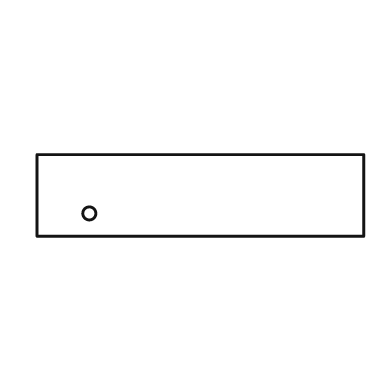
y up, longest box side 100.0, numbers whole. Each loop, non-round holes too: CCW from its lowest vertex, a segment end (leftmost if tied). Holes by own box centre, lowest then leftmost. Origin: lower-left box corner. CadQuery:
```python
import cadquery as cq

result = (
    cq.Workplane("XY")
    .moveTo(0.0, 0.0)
    .lineTo(100.0, 0.0)
    .lineTo(100.0, 25.0)
    .lineTo(0.0, 25.0)
    .close()
    .moveTo(16.0, 7.0)
    .circle(2.0)
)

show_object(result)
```